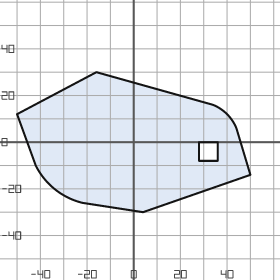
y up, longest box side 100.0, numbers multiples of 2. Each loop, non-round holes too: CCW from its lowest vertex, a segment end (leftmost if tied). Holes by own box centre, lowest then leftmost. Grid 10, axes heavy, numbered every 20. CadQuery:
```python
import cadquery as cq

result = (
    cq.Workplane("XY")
    .moveTo(4.0, -30.0)
    .lineTo(50.0, -14.0)
    .lineTo(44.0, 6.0)
    .threePointArc((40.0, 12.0), (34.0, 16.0))
    .lineTo(-16.0, 30.0)
    .lineTo(-50.0, 12.0)
    .lineTo(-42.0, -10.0)
    .threePointArc((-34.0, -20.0), (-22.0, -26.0))
    .close()
    .moveTo(28.0, -8.0)
    .lineTo(36.0, -8.0)
    .lineTo(36.0, 0.0)
    .lineTo(28.0, 0.0)
    .close()
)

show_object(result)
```